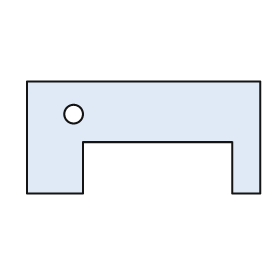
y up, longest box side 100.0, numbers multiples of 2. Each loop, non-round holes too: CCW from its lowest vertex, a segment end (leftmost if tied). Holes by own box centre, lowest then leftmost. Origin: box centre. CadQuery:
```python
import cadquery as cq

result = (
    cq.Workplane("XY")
    .moveTo(-50.0, -24.0)
    .lineTo(-26.0, -24.0)
    .lineTo(-26.0, -2.0)
    .lineTo(38.0, -2.0)
    .lineTo(38.0, -24.0)
    .lineTo(50.0, -24.0)
    .lineTo(50.0, 24.0)
    .lineTo(-50.0, 24.0)
    .close()
    .moveTo(-30.0, 10.0)
    .circle(4.0)
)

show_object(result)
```